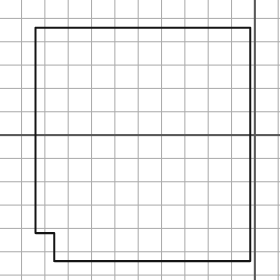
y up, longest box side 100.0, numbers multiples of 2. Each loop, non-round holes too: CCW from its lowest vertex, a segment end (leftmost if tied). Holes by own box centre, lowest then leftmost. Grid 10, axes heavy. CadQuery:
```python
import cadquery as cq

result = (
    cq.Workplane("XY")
    .moveTo(-86.0, -54.0)
    .lineTo(-2.0, -54.0)
    .lineTo(-2.0, 46.0)
    .lineTo(-94.0, 46.0)
    .lineTo(-94.0, -42.0)
    .lineTo(-86.0, -42.0)
    .close()
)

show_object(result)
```